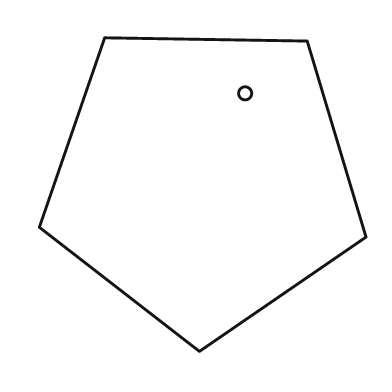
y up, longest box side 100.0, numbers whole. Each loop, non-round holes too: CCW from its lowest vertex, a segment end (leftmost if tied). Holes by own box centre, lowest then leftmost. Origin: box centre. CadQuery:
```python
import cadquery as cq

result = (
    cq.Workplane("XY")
    .moveTo(-1.0, -48.0)
    .lineTo(50.0, -13.0)
    .lineTo(32.0, 47.0)
    .lineTo(-30.0, 48.0)
    .lineTo(-50.0, -10.0)
    .close()
    .moveTo(13.0, 31.0)
    .circle(2.0)
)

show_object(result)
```